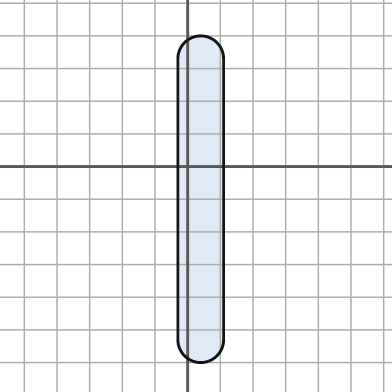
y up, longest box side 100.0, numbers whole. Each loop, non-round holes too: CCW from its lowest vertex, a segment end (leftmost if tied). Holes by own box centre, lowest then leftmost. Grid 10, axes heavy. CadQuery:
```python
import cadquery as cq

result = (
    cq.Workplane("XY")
    .moveTo(-3.0, -53.0)
    .threePointArc((4.0, -60.0), (11.0, -53.0))
    .lineTo(11.0, 33.0)
    .threePointArc((4.0, 40.0), (-3.0, 33.0))
    .close()
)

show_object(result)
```